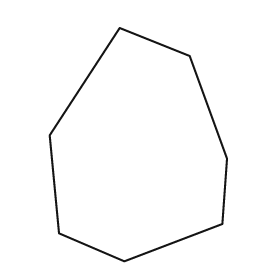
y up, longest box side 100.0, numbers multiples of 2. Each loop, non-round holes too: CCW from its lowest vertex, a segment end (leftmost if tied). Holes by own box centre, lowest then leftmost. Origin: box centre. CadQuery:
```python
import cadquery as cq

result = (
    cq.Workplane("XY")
    .moveTo(-6.0, -50.0)
    .lineTo(36.0, -34.0)
    .lineTo(38.0, -6.0)
    .lineTo(22.0, 38.0)
    .lineTo(-8.0, 50.0)
    .lineTo(-38.0, 4.0)
    .lineTo(-34.0, -38.0)
    .close()
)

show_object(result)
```